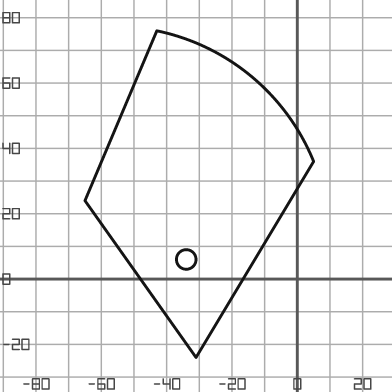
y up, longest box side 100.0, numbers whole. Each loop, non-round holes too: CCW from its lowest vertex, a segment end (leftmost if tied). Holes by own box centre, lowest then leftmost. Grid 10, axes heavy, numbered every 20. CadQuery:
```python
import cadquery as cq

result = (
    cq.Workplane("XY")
    .moveTo(-31.0, -24.0)
    .lineTo(5.0, 36.0)
    .threePointArc((-14.0, 62.0), (-43.0, 76.0))
    .lineTo(-65.0, 24.0)
    .close()
    .moveTo(-34.0, 6.0)
    .circle(3.0)
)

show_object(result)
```